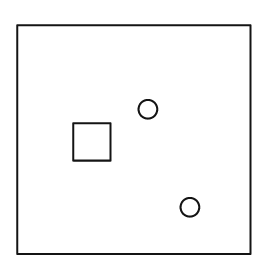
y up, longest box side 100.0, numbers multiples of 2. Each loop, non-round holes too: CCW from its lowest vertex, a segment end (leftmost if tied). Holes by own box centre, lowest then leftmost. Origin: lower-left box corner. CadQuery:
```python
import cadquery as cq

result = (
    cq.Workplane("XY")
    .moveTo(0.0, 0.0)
    .lineTo(100.0, 0.0)
    .lineTo(100.0, 98.0)
    .lineTo(0.0, 98.0)
    .close()
    .moveTo(74.0, 20.0)
    .circle(4.0)
    .moveTo(24.0, 40.0)
    .lineTo(40.0, 40.0)
    .lineTo(40.0, 56.0)
    .lineTo(24.0, 56.0)
    .close()
    .moveTo(56.0, 62.0)
    .circle(4.0)
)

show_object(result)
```